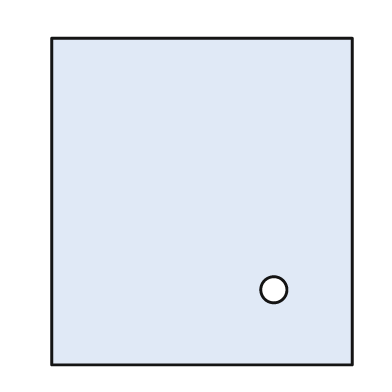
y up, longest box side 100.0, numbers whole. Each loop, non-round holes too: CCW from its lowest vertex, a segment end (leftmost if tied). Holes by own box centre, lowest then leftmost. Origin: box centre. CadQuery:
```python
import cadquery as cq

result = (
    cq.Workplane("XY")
    .moveTo(-46.0, -50.0)
    .lineTo(46.0, -50.0)
    .lineTo(46.0, 50.0)
    .lineTo(-46.0, 50.0)
    .close()
    .moveTo(22.0, -27.0)
    .circle(4.0)
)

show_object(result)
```